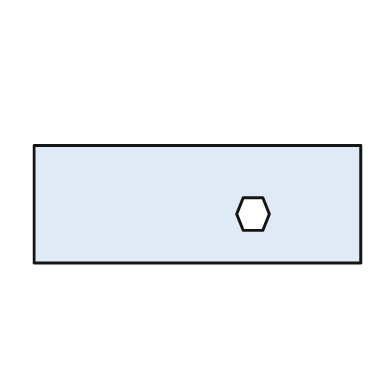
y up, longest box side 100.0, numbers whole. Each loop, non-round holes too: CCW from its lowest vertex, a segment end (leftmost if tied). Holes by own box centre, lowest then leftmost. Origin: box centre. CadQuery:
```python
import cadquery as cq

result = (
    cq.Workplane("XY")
    .moveTo(-50.0, -18.0)
    .lineTo(50.0, -18.0)
    .lineTo(50.0, 18.0)
    .lineTo(-50.0, 18.0)
    .close()
    .moveTo(14.0, -8.0)
    .lineTo(20.0, -8.0)
    .lineTo(22.0, -3.0)
    .lineTo(20.0, 2.0)
    .lineTo(14.0, 2.0)
    .lineTo(12.0, -3.0)
    .close()
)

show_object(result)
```